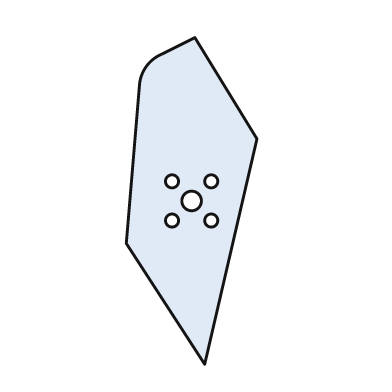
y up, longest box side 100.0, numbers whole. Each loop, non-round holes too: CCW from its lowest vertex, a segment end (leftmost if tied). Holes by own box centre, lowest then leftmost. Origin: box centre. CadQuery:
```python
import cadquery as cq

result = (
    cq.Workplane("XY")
    .moveTo(4.0, -50.0)
    .lineTo(20.0, 19.0)
    .lineTo(1.0, 50.0)
    .lineTo(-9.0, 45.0)
    .threePointArc((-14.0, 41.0), (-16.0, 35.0))
    .lineTo(-20.0, -13.0)
    .close()
    .moveTo(-6.0, -6.0)
    .circle(2.0)
    .moveTo(6.0, -6.0)
    .circle(2.0)
    .moveTo(0.0, 0.0)
    .circle(3.0)
    .moveTo(-6.0, 6.0)
    .circle(2.0)
    .moveTo(6.0, 6.0)
    .circle(2.0)
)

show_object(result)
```